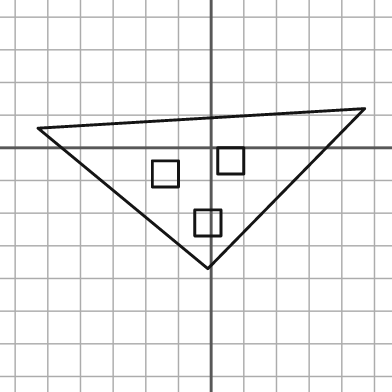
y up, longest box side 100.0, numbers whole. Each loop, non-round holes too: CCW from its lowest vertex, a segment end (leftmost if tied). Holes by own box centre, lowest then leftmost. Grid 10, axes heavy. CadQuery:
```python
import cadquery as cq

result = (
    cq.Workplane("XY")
    .moveTo(-1.0, -37.0)
    .lineTo(47.0, 12.0)
    .lineTo(-53.0, 6.0)
    .close()
    .moveTo(-5.0, -27.0)
    .lineTo(3.0, -27.0)
    .lineTo(3.0, -19.0)
    .lineTo(-5.0, -19.0)
    .close()
    .moveTo(-18.0, -12.0)
    .lineTo(-10.0, -12.0)
    .lineTo(-10.0, -4.0)
    .lineTo(-18.0, -4.0)
    .close()
    .moveTo(2.0, -8.0)
    .lineTo(10.0, -8.0)
    .lineTo(10.0, 0.0)
    .lineTo(2.0, 0.0)
    .close()
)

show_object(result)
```